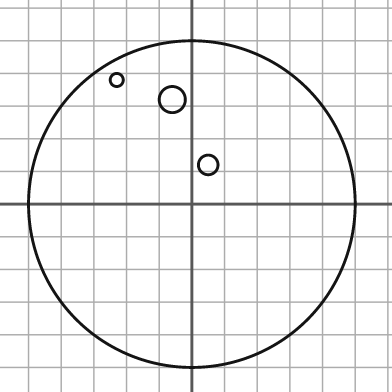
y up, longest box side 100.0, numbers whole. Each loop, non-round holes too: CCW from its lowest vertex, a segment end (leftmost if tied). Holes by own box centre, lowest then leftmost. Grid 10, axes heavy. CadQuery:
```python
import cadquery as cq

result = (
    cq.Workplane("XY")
    .moveTo(0.0, 0.0)
    .circle(50.0)
    .moveTo(5.0, 12.0)
    .circle(3.0)
    .moveTo(-6.0, 32.0)
    .circle(4.0)
    .moveTo(-23.0, 38.0)
    .circle(2.0)
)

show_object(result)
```